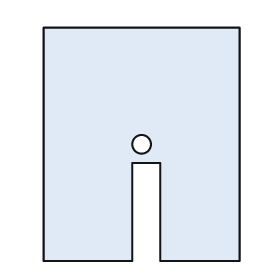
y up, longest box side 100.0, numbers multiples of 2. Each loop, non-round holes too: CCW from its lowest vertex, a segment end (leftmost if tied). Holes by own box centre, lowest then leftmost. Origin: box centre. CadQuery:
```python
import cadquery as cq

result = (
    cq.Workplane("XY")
    .moveTo(-42.0, -50.0)
    .lineTo(-4.0, -50.0)
    .lineTo(-4.0, -8.0)
    .lineTo(8.0, -8.0)
    .lineTo(8.0, -50.0)
    .lineTo(42.0, -50.0)
    .lineTo(42.0, 50.0)
    .lineTo(-42.0, 50.0)
    .close()
    .moveTo(0.0, 0.0)
    .circle(4.0)
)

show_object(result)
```